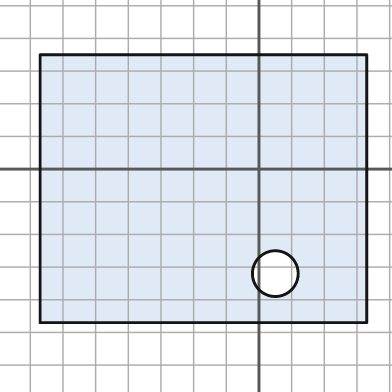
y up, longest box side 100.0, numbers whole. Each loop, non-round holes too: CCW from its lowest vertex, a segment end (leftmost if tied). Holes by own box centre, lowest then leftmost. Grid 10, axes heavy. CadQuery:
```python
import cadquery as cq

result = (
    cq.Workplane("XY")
    .moveTo(-67.0, -47.0)
    .lineTo(33.0, -47.0)
    .lineTo(33.0, 35.0)
    .lineTo(-67.0, 35.0)
    .close()
    .moveTo(5.0, -32.0)
    .circle(7.0)
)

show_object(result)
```